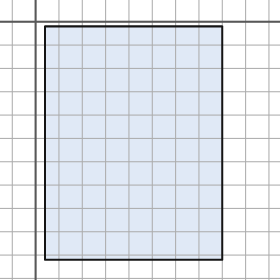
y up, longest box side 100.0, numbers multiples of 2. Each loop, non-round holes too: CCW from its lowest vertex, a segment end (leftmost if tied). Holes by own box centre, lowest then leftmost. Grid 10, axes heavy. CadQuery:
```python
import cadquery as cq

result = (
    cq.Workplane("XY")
    .moveTo(4.0, -102.0)
    .lineTo(80.0, -102.0)
    .lineTo(80.0, -2.0)
    .lineTo(4.0, -2.0)
    .close()
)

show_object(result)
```